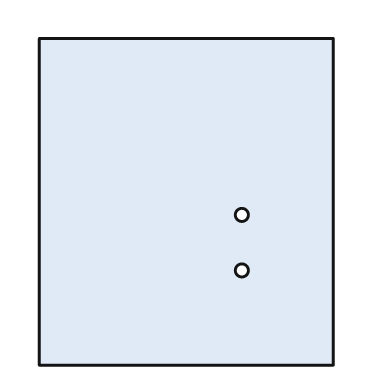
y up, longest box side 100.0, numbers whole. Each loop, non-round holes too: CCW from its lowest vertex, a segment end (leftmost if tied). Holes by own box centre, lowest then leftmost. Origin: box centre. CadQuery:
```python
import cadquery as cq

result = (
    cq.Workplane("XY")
    .moveTo(-45.0, -50.0)
    .lineTo(45.0, -50.0)
    .lineTo(45.0, 50.0)
    .lineTo(-45.0, 50.0)
    .close()
    .moveTo(17.0, -21.0)
    .circle(2.0)
    .moveTo(17.0, -4.0)
    .circle(2.0)
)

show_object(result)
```